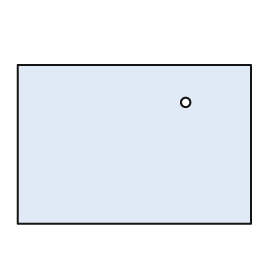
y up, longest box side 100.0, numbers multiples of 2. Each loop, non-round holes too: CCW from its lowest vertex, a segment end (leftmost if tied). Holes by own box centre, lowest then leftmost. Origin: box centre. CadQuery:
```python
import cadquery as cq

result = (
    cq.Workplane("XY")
    .moveTo(-50.0, -34.0)
    .lineTo(50.0, -34.0)
    .lineTo(50.0, 34.0)
    .lineTo(-50.0, 34.0)
    .close()
    .moveTo(22.0, 18.0)
    .circle(2.0)
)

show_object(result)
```